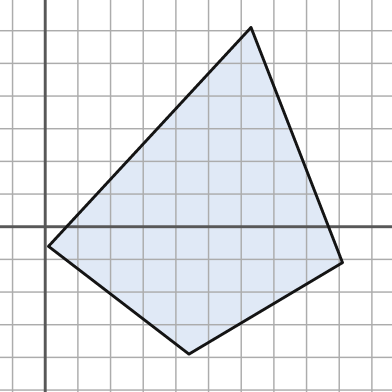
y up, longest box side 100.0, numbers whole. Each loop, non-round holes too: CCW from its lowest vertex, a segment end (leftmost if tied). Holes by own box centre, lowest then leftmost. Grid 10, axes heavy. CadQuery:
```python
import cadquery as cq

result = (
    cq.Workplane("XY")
    .moveTo(44.0, -39.0)
    .lineTo(91.0, -11.0)
    .lineTo(63.0, 61.0)
    .lineTo(1.0, -6.0)
    .close()
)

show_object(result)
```